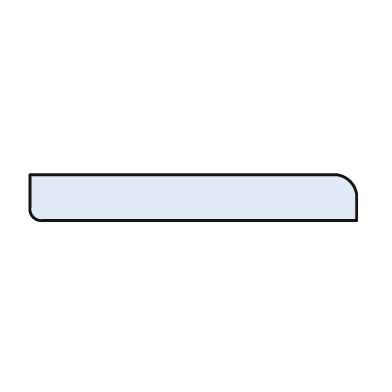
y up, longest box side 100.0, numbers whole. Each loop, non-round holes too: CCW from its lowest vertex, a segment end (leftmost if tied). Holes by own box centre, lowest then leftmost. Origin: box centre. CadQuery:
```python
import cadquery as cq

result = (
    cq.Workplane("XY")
    .moveTo(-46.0, -7.0)
    .lineTo(50.0, -7.0)
    .lineTo(50.0, 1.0)
    .threePointArc((48.0, 5.0), (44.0, 7.0))
    .lineTo(-50.0, 7.0)
    .lineTo(-50.0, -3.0)
    .threePointArc((-49.0, -6.0), (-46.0, -7.0))
    .close()
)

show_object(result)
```